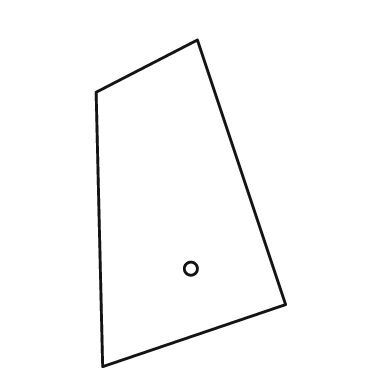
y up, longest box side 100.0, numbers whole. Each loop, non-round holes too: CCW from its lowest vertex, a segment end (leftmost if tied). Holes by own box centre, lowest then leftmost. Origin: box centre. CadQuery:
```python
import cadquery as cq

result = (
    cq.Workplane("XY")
    .moveTo(-27.0, -50.0)
    .lineTo(29.0, -31.0)
    .lineTo(2.0, 50.0)
    .lineTo(-29.0, 34.0)
    .close()
    .moveTo(0.0, -20.0)
    .circle(2.0)
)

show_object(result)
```